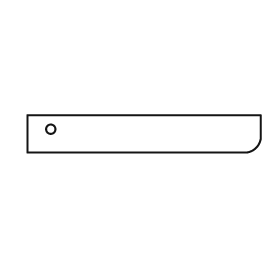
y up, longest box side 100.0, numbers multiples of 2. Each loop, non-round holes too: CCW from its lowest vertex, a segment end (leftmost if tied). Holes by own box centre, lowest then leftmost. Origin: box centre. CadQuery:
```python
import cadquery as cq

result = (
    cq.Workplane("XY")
    .moveTo(-50.0, -8.0)
    .lineTo(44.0, -8.0)
    .threePointArc((48.0, -6.0), (50.0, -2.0))
    .lineTo(50.0, 8.0)
    .lineTo(-50.0, 8.0)
    .close()
    .moveTo(-40.0, 2.0)
    .circle(2.0)
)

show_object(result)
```